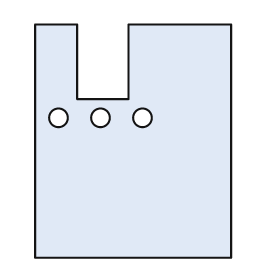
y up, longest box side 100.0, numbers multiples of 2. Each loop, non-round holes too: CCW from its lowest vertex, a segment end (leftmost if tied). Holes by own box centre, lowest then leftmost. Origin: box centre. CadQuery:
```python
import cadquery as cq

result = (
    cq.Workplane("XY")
    .moveTo(-42.0, -50.0)
    .lineTo(42.0, -50.0)
    .lineTo(42.0, 50.0)
    .lineTo(-2.0, 50.0)
    .lineTo(-2.0, 18.0)
    .lineTo(-24.0, 18.0)
    .lineTo(-24.0, 50.0)
    .lineTo(-42.0, 50.0)
    .close()
    .moveTo(-32.0, 10.0)
    .circle(4.0)
    .moveTo(-14.0, 10.0)
    .circle(4.0)
    .moveTo(4.0, 10.0)
    .circle(4.0)
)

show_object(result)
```